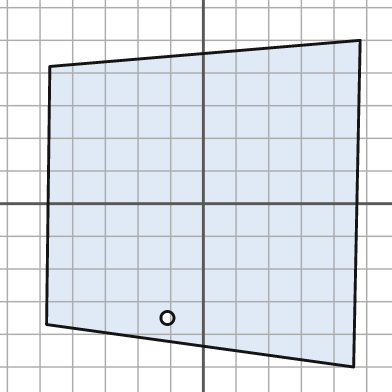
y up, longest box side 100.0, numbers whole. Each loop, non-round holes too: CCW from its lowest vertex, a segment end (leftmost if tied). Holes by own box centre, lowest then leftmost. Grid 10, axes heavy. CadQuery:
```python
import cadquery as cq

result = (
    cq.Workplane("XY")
    .moveTo(46.0, -50.0)
    .lineTo(48.0, 50.0)
    .lineTo(-47.0, 42.0)
    .lineTo(-48.0, -37.0)
    .close()
    .moveTo(-11.0, -35.0)
    .circle(2.0)
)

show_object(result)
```